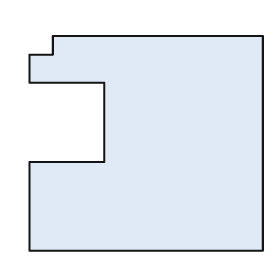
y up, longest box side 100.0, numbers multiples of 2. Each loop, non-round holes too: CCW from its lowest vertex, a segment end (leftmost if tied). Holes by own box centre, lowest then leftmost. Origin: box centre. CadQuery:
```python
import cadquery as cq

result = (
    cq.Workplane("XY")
    .moveTo(-50.0, -46.0)
    .lineTo(50.0, -46.0)
    .lineTo(50.0, 46.0)
    .lineTo(-40.0, 46.0)
    .lineTo(-40.0, 38.0)
    .lineTo(-50.0, 38.0)
    .lineTo(-50.0, 26.0)
    .lineTo(-18.0, 26.0)
    .lineTo(-18.0, -8.0)
    .lineTo(-50.0, -8.0)
    .close()
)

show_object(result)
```